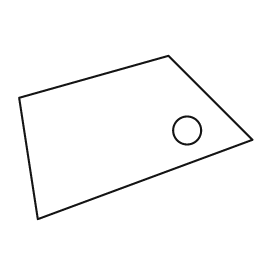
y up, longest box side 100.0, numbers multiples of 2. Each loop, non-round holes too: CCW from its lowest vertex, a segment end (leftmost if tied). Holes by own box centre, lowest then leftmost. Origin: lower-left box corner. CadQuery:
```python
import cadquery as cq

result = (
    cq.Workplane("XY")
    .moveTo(8.0, 0.0)
    .lineTo(100.0, 34.0)
    .lineTo(64.0, 70.0)
    .lineTo(0.0, 52.0)
    .close()
    .moveTo(72.0, 38.0)
    .circle(6.0)
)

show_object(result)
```